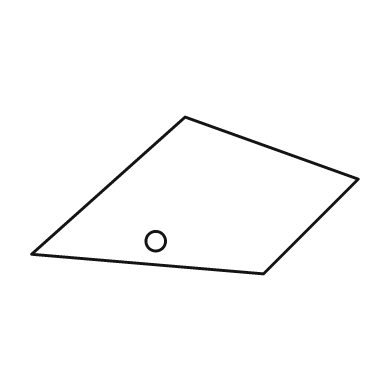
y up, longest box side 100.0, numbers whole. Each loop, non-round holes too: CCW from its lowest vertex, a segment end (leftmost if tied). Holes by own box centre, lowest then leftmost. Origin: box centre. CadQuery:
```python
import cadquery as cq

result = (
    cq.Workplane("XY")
    .moveTo(21.0, -24.0)
    .lineTo(50.0, 5.0)
    .lineTo(-3.0, 24.0)
    .lineTo(-50.0, -18.0)
    .close()
    .moveTo(-12.0, -14.0)
    .circle(3.0)
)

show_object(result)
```